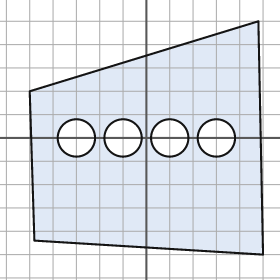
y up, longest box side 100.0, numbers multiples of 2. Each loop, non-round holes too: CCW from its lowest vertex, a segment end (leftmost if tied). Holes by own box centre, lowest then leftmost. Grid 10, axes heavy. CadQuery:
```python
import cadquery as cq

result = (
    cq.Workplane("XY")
    .moveTo(50.0, -50.0)
    .lineTo(48.0, 50.0)
    .lineTo(-50.0, 20.0)
    .lineTo(-48.0, -44.0)
    .close()
    .moveTo(-30.0, 0.0)
    .circle(8.0)
    .moveTo(-10.0, 0.0)
    .circle(8.0)
    .moveTo(10.0, 0.0)
    .circle(8.0)
    .moveTo(30.0, 0.0)
    .circle(8.0)
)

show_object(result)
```